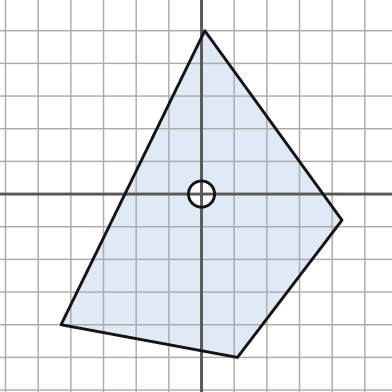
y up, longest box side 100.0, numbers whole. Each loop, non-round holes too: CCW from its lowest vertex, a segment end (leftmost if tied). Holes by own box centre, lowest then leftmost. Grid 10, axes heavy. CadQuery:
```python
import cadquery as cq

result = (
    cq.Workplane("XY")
    .moveTo(11.0, -50.0)
    .lineTo(43.0, -8.0)
    .lineTo(1.0, 50.0)
    .lineTo(-43.0, -40.0)
    .close()
    .moveTo(0.0, 0.0)
    .circle(4.0)
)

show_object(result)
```